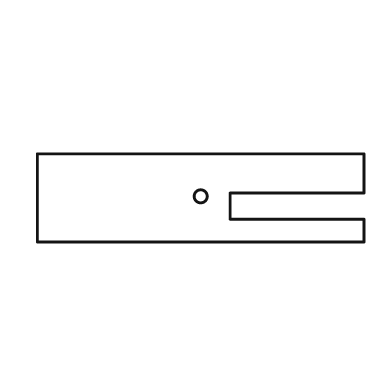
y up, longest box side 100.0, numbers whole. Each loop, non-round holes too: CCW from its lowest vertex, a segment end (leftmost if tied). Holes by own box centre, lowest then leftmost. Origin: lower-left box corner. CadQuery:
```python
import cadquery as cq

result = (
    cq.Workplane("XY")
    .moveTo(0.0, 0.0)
    .lineTo(100.0, 0.0)
    .lineTo(100.0, 7.0)
    .lineTo(59.0, 7.0)
    .lineTo(59.0, 15.0)
    .lineTo(100.0, 15.0)
    .lineTo(100.0, 27.0)
    .lineTo(0.0, 27.0)
    .close()
    .moveTo(50.0, 14.0)
    .circle(2.0)
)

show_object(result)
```